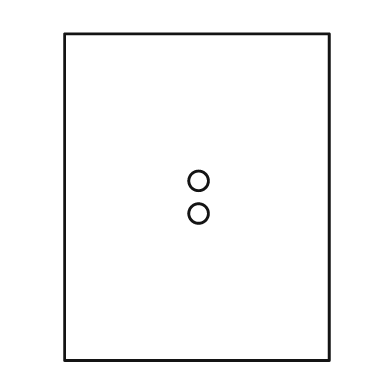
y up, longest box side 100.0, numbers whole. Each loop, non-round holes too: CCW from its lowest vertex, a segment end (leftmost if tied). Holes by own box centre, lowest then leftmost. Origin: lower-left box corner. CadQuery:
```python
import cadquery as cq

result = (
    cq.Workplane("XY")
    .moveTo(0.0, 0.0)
    .lineTo(81.0, 0.0)
    .lineTo(81.0, 100.0)
    .lineTo(0.0, 100.0)
    .close()
    .moveTo(41.0, 45.0)
    .circle(3.0)
    .moveTo(41.0, 55.0)
    .circle(3.0)
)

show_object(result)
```